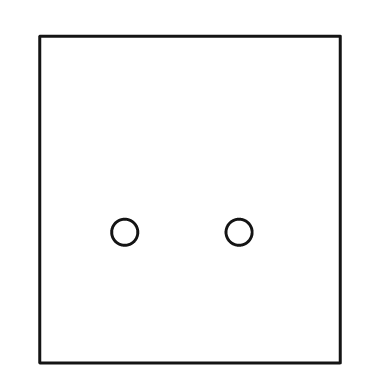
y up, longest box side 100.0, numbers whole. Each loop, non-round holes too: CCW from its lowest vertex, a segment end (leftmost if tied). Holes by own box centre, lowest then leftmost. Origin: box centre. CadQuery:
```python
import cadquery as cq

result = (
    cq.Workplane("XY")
    .moveTo(-46.0, -50.0)
    .lineTo(46.0, -50.0)
    .lineTo(46.0, 50.0)
    .lineTo(-46.0, 50.0)
    .close()
    .moveTo(-20.0, -10.0)
    .circle(4.0)
    .moveTo(15.0, -10.0)
    .circle(4.0)
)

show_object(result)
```